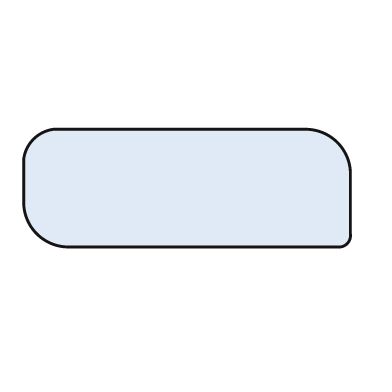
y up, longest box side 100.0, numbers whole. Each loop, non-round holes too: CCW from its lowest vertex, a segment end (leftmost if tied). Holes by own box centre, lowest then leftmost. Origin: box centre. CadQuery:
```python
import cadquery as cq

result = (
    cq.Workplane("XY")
    .moveTo(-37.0, -18.0)
    .lineTo(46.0, -18.0)
    .threePointArc((49.0, -17.0), (50.0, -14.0))
    .lineTo(50.0, 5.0)
    .threePointArc((46.0, 14.0), (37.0, 18.0))
    .lineTo(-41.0, 18.0)
    .threePointArc((-47.0, 15.0), (-50.0, 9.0))
    .lineTo(-50.0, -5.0)
    .threePointArc((-46.0, -14.0), (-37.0, -18.0))
    .close()
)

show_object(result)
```